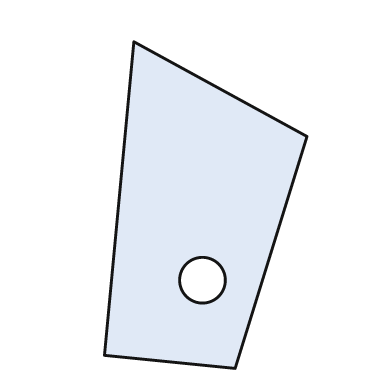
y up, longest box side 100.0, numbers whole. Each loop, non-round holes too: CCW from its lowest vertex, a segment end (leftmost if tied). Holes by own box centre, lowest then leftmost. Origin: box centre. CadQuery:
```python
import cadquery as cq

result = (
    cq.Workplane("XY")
    .moveTo(9.0, -50.0)
    .lineTo(31.0, 21.0)
    .lineTo(-22.0, 50.0)
    .lineTo(-31.0, -46.0)
    .close()
    .moveTo(-1.0, -23.0)
    .circle(7.0)
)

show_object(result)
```